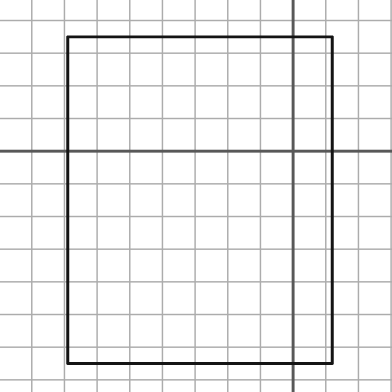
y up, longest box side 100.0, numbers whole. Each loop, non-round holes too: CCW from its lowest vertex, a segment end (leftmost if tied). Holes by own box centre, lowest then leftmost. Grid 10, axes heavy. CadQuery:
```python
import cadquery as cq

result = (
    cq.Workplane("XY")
    .moveTo(-69.0, -65.0)
    .lineTo(12.0, -65.0)
    .lineTo(12.0, 35.0)
    .lineTo(-69.0, 35.0)
    .close()
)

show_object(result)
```